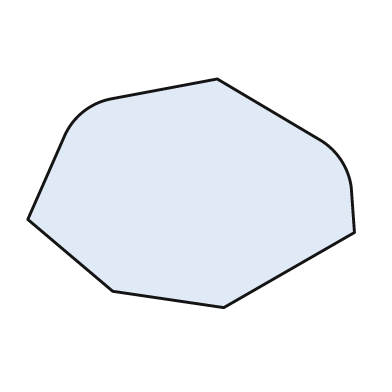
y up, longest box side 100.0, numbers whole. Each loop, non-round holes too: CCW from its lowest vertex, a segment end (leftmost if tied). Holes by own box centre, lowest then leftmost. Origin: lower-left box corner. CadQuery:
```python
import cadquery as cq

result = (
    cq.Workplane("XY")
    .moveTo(60.0, 0.0)
    .lineTo(100.0, 23.0)
    .lineTo(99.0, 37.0)
    .threePointArc((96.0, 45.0), (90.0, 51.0))
    .lineTo(58.0, 70.0)
    .lineTo(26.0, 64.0)
    .threePointArc((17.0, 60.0), (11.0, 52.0))
    .lineTo(0.0, 27.0)
    .lineTo(26.0, 5.0)
    .close()
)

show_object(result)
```